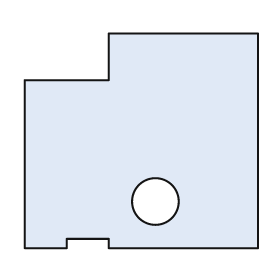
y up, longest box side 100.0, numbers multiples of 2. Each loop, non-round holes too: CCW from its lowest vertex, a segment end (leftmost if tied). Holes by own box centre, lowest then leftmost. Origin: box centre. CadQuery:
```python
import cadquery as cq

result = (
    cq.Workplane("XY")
    .moveTo(-50.0, -46.0)
    .lineTo(-32.0, -46.0)
    .lineTo(-32.0, -42.0)
    .lineTo(-14.0, -42.0)
    .lineTo(-14.0, -46.0)
    .lineTo(50.0, -46.0)
    .lineTo(50.0, 46.0)
    .lineTo(-14.0, 46.0)
    .lineTo(-14.0, 26.0)
    .lineTo(-50.0, 26.0)
    .close()
    .moveTo(6.0, -26.0)
    .circle(10.0)
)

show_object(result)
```